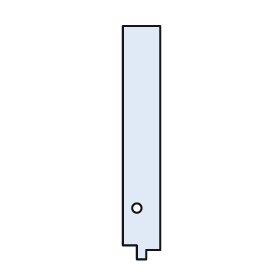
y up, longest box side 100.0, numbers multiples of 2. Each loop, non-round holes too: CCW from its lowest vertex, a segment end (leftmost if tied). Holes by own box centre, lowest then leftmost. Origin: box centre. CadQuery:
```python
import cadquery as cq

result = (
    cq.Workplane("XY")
    .moveTo(-2.0, -50.0)
    .lineTo(2.0, -50.0)
    .lineTo(2.0, -46.0)
    .lineTo(8.0, -46.0)
    .lineTo(8.0, 50.0)
    .lineTo(-8.0, 50.0)
    .lineTo(-8.0, -44.0)
    .lineTo(-2.0, -44.0)
    .close()
    .moveTo(-2.0, -28.0)
    .circle(2.0)
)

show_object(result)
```